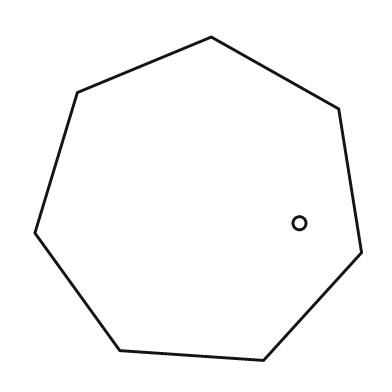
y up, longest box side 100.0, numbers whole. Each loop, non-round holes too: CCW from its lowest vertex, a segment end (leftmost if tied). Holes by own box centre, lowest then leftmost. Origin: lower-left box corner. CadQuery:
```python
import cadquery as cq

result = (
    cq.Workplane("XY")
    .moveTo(70.0, 0.0)
    .lineTo(100.0, 33.0)
    .lineTo(93.0, 77.0)
    .lineTo(54.0, 99.0)
    .lineTo(13.0, 82.0)
    .lineTo(0.0, 39.0)
    .lineTo(26.0, 3.0)
    .close()
    .moveTo(81.0, 42.0)
    .circle(2.0)
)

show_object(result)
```